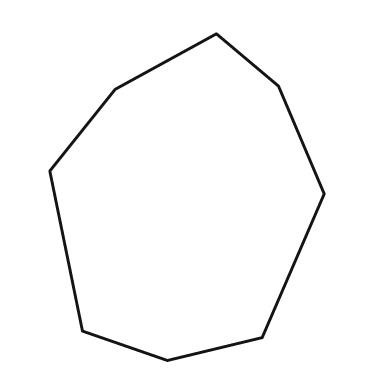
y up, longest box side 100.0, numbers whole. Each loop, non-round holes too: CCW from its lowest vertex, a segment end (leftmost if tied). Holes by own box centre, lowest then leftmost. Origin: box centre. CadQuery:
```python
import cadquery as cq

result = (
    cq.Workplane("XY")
    .moveTo(-6.0, -50.0)
    .lineTo(23.0, -43.0)
    .lineTo(42.0, 1.0)
    .lineTo(28.0, 34.0)
    .lineTo(9.0, 50.0)
    .lineTo(-22.0, 33.0)
    .lineTo(-42.0, 8.0)
    .lineTo(-32.0, -41.0)
    .close()
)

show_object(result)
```